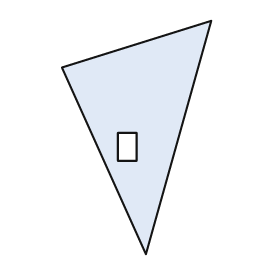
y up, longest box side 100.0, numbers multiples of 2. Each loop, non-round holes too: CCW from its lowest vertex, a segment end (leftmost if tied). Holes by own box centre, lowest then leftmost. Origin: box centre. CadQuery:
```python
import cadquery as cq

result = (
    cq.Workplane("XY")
    .moveTo(4.0, -50.0)
    .lineTo(32.0, 50.0)
    .lineTo(-32.0, 30.0)
    .close()
    .moveTo(-8.0, -10.0)
    .lineTo(0.0, -10.0)
    .lineTo(0.0, 2.0)
    .lineTo(-8.0, 2.0)
    .close()
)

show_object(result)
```